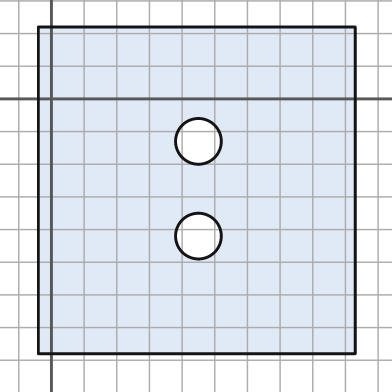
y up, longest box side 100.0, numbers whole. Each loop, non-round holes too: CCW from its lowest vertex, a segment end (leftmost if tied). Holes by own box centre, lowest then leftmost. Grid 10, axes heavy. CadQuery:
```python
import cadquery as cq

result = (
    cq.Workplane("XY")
    .moveTo(-4.0, -78.0)
    .lineTo(93.0, -78.0)
    .lineTo(93.0, 22.0)
    .lineTo(-4.0, 22.0)
    .close()
    .moveTo(45.0, -42.0)
    .circle(7.0)
    .moveTo(45.0, -13.0)
    .circle(7.0)
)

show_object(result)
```